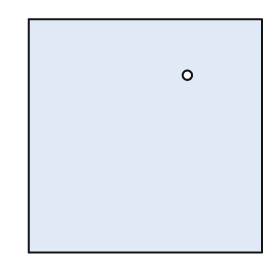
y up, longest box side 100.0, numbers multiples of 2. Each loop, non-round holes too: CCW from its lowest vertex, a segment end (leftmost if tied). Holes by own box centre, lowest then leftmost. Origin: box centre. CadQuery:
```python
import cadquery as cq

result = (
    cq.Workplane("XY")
    .moveTo(-50.0, -50.0)
    .lineTo(50.0, -50.0)
    .lineTo(50.0, 50.0)
    .lineTo(-50.0, 50.0)
    .close()
    .moveTo(18.0, 26.0)
    .circle(2.0)
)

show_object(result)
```